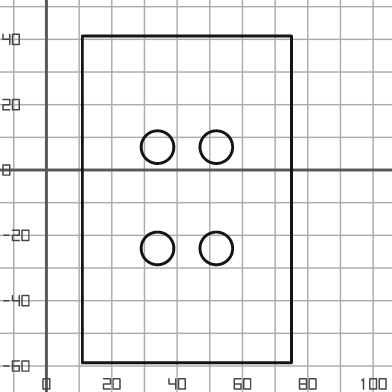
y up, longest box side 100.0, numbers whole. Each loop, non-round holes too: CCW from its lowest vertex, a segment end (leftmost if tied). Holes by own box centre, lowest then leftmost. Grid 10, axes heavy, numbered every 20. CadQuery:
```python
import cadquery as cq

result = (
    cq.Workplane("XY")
    .moveTo(11.0, -59.0)
    .lineTo(75.0, -59.0)
    .lineTo(75.0, 41.0)
    .lineTo(11.0, 41.0)
    .close()
    .moveTo(34.0, -24.0)
    .circle(5.0)
    .moveTo(52.0, -24.0)
    .circle(5.0)
    .moveTo(34.0, 7.0)
    .circle(5.0)
    .moveTo(52.0, 7.0)
    .circle(5.0)
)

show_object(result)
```